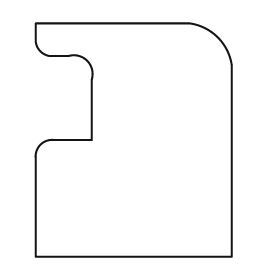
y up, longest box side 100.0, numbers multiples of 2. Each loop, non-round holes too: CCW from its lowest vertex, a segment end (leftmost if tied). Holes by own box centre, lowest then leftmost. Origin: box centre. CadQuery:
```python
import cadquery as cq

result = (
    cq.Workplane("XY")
    .moveTo(-42.0, -50.0)
    .lineTo(42.0, -50.0)
    .lineTo(42.0, 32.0)
    .threePointArc((36.0, 44.0), (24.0, 50.0))
    .lineTo(-42.0, 50.0)
    .lineTo(-42.0, 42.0)
    .threePointArc((-40.0, 38.0), (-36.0, 36.0))
    .lineTo(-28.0, 36.0)
    .threePointArc((-20.0, 34.0), (-18.0, 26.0))
    .lineTo(-18.0, 0.0)
    .lineTo(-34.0, 0.0)
    .threePointArc((-40.0, -2.0), (-42.0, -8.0))
    .close()
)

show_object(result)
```